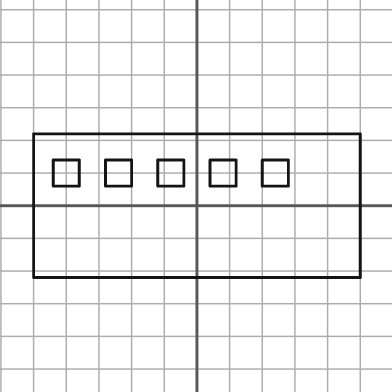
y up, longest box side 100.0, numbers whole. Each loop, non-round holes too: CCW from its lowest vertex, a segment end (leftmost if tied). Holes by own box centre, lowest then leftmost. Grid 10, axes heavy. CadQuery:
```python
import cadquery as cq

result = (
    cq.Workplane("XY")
    .moveTo(-50.0, -22.0)
    .lineTo(50.0, -22.0)
    .lineTo(50.0, 22.0)
    .lineTo(-50.0, 22.0)
    .close()
    .moveTo(-44.0, 6.0)
    .lineTo(-36.0, 6.0)
    .lineTo(-36.0, 14.0)
    .lineTo(-44.0, 14.0)
    .close()
    .moveTo(-28.0, 6.0)
    .lineTo(-20.0, 6.0)
    .lineTo(-20.0, 14.0)
    .lineTo(-28.0, 14.0)
    .close()
    .moveTo(-12.0, 6.0)
    .lineTo(-4.0, 6.0)
    .lineTo(-4.0, 14.0)
    .lineTo(-12.0, 14.0)
    .close()
    .moveTo(4.0, 6.0)
    .lineTo(12.0, 6.0)
    .lineTo(12.0, 14.0)
    .lineTo(4.0, 14.0)
    .close()
    .moveTo(20.0, 6.0)
    .lineTo(28.0, 6.0)
    .lineTo(28.0, 14.0)
    .lineTo(20.0, 14.0)
    .close()
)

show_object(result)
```